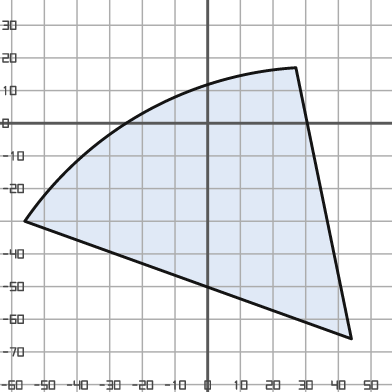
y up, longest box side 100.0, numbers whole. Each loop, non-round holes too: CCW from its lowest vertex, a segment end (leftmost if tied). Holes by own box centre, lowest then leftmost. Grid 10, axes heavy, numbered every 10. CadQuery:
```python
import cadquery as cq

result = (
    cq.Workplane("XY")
    .moveTo(44.0, -66.0)
    .lineTo(27.0, 17.0)
    .threePointArc((-20.0, 3.0), (-56.0, -30.0))
    .close()
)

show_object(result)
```